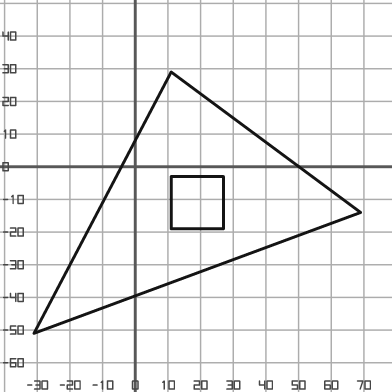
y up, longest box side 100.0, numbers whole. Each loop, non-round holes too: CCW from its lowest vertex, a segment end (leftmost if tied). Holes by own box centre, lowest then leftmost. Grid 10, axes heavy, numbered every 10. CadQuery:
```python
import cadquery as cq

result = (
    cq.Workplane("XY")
    .moveTo(-31.0, -51.0)
    .lineTo(69.0, -14.0)
    .lineTo(11.0, 29.0)
    .close()
    .moveTo(11.0, -19.0)
    .lineTo(27.0, -19.0)
    .lineTo(27.0, -3.0)
    .lineTo(11.0, -3.0)
    .close()
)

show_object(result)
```